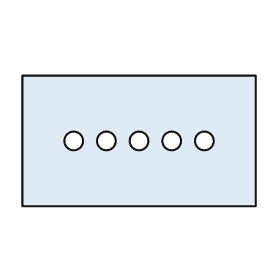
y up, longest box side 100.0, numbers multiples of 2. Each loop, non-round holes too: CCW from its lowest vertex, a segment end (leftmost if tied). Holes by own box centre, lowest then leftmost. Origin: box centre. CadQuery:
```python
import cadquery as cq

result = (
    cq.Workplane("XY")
    .moveTo(-50.0, -28.0)
    .lineTo(50.0, -28.0)
    .lineTo(50.0, 28.0)
    .lineTo(-50.0, 28.0)
    .close()
    .moveTo(-28.0, 0.0)
    .circle(4.0)
    .moveTo(-14.0, 0.0)
    .circle(4.0)
    .moveTo(0.0, 0.0)
    .circle(4.0)
    .moveTo(14.0, 0.0)
    .circle(4.0)
    .moveTo(28.0, 0.0)
    .circle(4.0)
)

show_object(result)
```